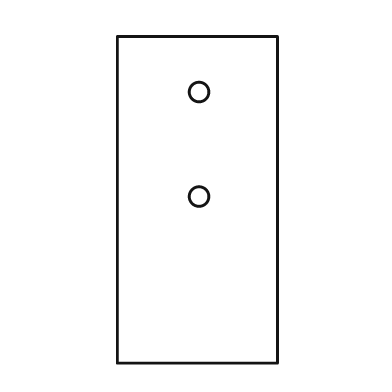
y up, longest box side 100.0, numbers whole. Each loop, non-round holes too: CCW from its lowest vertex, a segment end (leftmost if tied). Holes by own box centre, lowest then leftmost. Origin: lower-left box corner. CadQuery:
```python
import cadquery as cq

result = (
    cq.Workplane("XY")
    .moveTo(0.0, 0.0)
    .lineTo(49.0, 0.0)
    .lineTo(49.0, 100.0)
    .lineTo(0.0, 100.0)
    .close()
    .moveTo(25.0, 51.0)
    .circle(3.0)
    .moveTo(25.0, 83.0)
    .circle(3.0)
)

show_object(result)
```